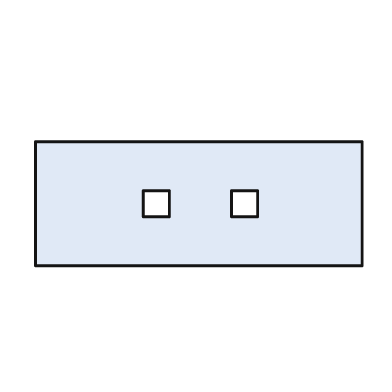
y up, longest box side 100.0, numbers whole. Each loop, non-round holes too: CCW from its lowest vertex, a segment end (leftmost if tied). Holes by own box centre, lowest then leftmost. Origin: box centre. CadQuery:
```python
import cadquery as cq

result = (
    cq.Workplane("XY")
    .moveTo(-50.0, -19.0)
    .lineTo(50.0, -19.0)
    .lineTo(50.0, 19.0)
    .lineTo(-50.0, 19.0)
    .close()
    .moveTo(-17.0, -4.0)
    .lineTo(-9.0, -4.0)
    .lineTo(-9.0, 4.0)
    .lineTo(-17.0, 4.0)
    .close()
    .moveTo(10.0, -4.0)
    .lineTo(18.0, -4.0)
    .lineTo(18.0, 4.0)
    .lineTo(10.0, 4.0)
    .close()
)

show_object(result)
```